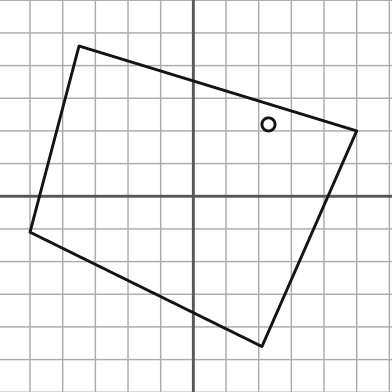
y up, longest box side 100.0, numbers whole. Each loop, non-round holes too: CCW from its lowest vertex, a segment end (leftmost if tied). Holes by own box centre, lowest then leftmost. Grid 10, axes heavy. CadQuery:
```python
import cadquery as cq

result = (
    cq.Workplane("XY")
    .moveTo(21.0, -46.0)
    .lineTo(50.0, 20.0)
    .lineTo(-35.0, 46.0)
    .lineTo(-50.0, -11.0)
    .close()
    .moveTo(23.0, 22.0)
    .circle(2.0)
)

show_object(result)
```